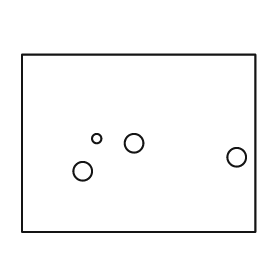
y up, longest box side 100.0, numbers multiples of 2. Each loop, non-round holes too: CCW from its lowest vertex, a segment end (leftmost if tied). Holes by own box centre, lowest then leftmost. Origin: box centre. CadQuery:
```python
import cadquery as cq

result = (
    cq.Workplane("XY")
    .moveTo(-50.0, -38.0)
    .lineTo(50.0, -38.0)
    .lineTo(50.0, 38.0)
    .lineTo(-50.0, 38.0)
    .close()
    .moveTo(-24.0, -12.0)
    .circle(4.0)
    .moveTo(42.0, -6.0)
    .circle(4.0)
    .moveTo(-2.0, 0.0)
    .circle(4.0)
    .moveTo(-18.0, 2.0)
    .circle(2.0)
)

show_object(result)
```